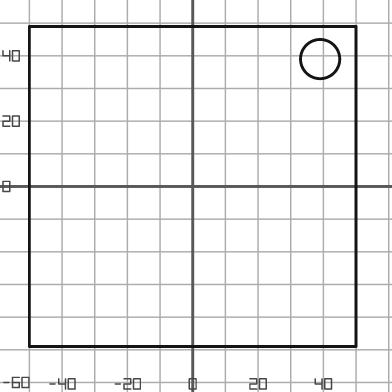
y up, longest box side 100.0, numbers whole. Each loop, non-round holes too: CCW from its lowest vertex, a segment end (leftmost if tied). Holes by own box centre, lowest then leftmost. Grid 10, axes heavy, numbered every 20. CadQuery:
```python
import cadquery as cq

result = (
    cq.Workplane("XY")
    .moveTo(-50.0, -49.0)
    .lineTo(50.0, -49.0)
    .lineTo(50.0, 49.0)
    .lineTo(-50.0, 49.0)
    .close()
    .moveTo(39.0, 39.0)
    .circle(6.0)
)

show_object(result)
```